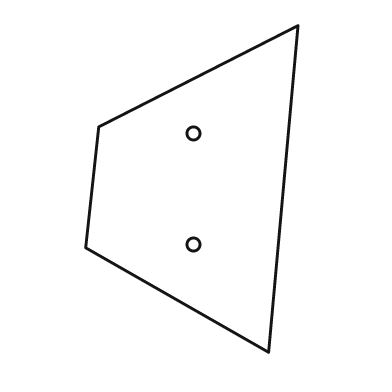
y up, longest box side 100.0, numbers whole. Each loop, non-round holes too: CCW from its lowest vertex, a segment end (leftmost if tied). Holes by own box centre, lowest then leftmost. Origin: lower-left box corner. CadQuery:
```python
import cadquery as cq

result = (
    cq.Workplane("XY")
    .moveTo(56.0, 0.0)
    .lineTo(65.0, 100.0)
    .lineTo(4.0, 69.0)
    .lineTo(0.0, 32.0)
    .close()
    .moveTo(33.0, 33.0)
    .circle(2.0)
    .moveTo(33.0, 67.0)
    .circle(2.0)
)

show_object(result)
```